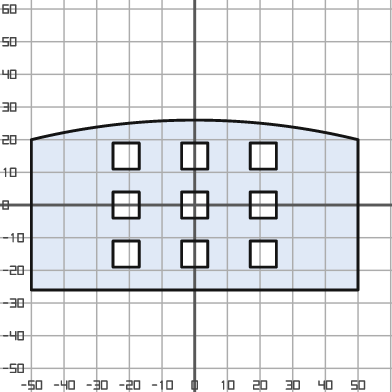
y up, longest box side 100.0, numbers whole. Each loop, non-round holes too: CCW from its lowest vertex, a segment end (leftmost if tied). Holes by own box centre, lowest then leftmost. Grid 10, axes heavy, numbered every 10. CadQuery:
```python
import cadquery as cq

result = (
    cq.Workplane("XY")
    .moveTo(-50.0, -26.0)
    .lineTo(50.0, -26.0)
    .lineTo(50.0, 20.0)
    .threePointArc((0.0, 26.0), (-50.0, 20.0))
    .close()
    .moveTo(-25.0, -19.0)
    .lineTo(-17.0, -19.0)
    .lineTo(-17.0, -11.0)
    .lineTo(-25.0, -11.0)
    .close()
    .moveTo(-4.0, -19.0)
    .lineTo(4.0, -19.0)
    .lineTo(4.0, -11.0)
    .lineTo(-4.0, -11.0)
    .close()
    .moveTo(17.0, -19.0)
    .lineTo(25.0, -19.0)
    .lineTo(25.0, -11.0)
    .lineTo(17.0, -11.0)
    .close()
    .moveTo(-25.0, -4.0)
    .lineTo(-17.0, -4.0)
    .lineTo(-17.0, 4.0)
    .lineTo(-25.0, 4.0)
    .close()
    .moveTo(-4.0, -4.0)
    .lineTo(4.0, -4.0)
    .lineTo(4.0, 4.0)
    .lineTo(-4.0, 4.0)
    .close()
    .moveTo(17.0, -4.0)
    .lineTo(25.0, -4.0)
    .lineTo(25.0, 4.0)
    .lineTo(17.0, 4.0)
    .close()
    .moveTo(-25.0, 11.0)
    .lineTo(-17.0, 11.0)
    .lineTo(-17.0, 19.0)
    .lineTo(-25.0, 19.0)
    .close()
    .moveTo(-4.0, 11.0)
    .lineTo(4.0, 11.0)
    .lineTo(4.0, 19.0)
    .lineTo(-4.0, 19.0)
    .close()
    .moveTo(17.0, 11.0)
    .lineTo(25.0, 11.0)
    .lineTo(25.0, 19.0)
    .lineTo(17.0, 19.0)
    .close()
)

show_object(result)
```